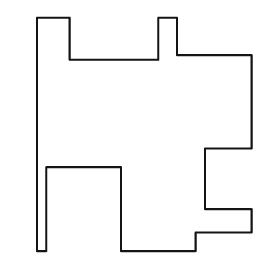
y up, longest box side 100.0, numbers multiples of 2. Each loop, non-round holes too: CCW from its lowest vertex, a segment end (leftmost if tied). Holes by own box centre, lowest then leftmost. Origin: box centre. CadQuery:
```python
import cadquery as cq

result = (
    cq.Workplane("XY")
    .moveTo(-46.0, -50.0)
    .lineTo(-42.0, -50.0)
    .lineTo(-42.0, -14.0)
    .lineTo(-10.0, -14.0)
    .lineTo(-10.0, -50.0)
    .lineTo(22.0, -50.0)
    .lineTo(22.0, -42.0)
    .lineTo(46.0, -42.0)
    .lineTo(46.0, -32.0)
    .lineTo(26.0, -32.0)
    .lineTo(26.0, -6.0)
    .lineTo(46.0, -6.0)
    .lineTo(46.0, 34.0)
    .lineTo(14.0, 34.0)
    .lineTo(14.0, 50.0)
    .lineTo(6.0, 50.0)
    .lineTo(6.0, 32.0)
    .lineTo(-32.0, 32.0)
    .lineTo(-32.0, 50.0)
    .lineTo(-46.0, 50.0)
    .close()
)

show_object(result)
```